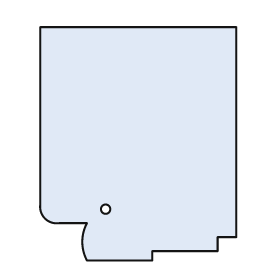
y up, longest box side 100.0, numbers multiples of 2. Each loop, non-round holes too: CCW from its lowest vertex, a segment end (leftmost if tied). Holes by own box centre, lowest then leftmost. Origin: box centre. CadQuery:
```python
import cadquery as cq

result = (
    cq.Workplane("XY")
    .moveTo(-22.0, -50.0)
    .lineTo(6.0, -50.0)
    .lineTo(6.0, -46.0)
    .lineTo(34.0, -46.0)
    .lineTo(34.0, -40.0)
    .lineTo(42.0, -40.0)
    .lineTo(42.0, 50.0)
    .lineTo(-42.0, 50.0)
    .lineTo(-42.0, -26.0)
    .threePointArc((-40.0, -32.0), (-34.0, -34.0))
    .lineTo(-22.0, -34.0)
    .threePointArc((-24.0, -42.0), (-22.0, -50.0))
    .close()
    .moveTo(-14.0, -28.0)
    .circle(2.0)
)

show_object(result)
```